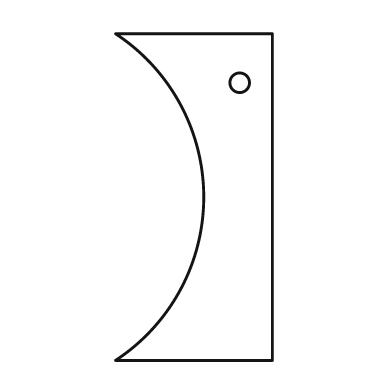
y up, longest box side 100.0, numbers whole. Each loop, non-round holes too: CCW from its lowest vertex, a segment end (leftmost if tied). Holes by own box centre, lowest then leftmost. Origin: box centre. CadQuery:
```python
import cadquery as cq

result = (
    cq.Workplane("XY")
    .moveTo(-24.0, -50.0)
    .lineTo(24.0, -50.0)
    .lineTo(24.0, 50.0)
    .lineTo(-24.0, 50.0)
    .threePointArc((3.0, 0.0), (-24.0, -50.0))
    .close()
    .moveTo(14.0, 35.0)
    .circle(3.0)
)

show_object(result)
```